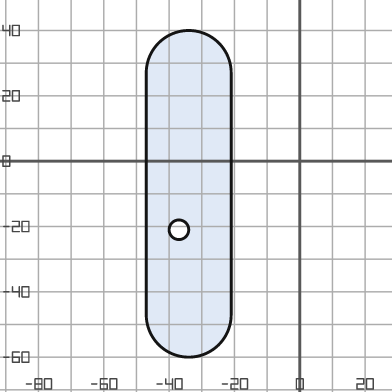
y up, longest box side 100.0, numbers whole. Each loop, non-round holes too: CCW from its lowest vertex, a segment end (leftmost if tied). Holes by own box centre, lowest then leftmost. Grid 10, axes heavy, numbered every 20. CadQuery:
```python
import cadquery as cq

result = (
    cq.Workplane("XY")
    .moveTo(-47.0, -47.0)
    .threePointArc((-34.0, -60.0), (-21.0, -47.0))
    .lineTo(-21.0, 27.0)
    .threePointArc((-34.0, 40.0), (-47.0, 27.0))
    .close()
    .moveTo(-37.0, -21.0)
    .circle(3.0)
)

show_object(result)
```